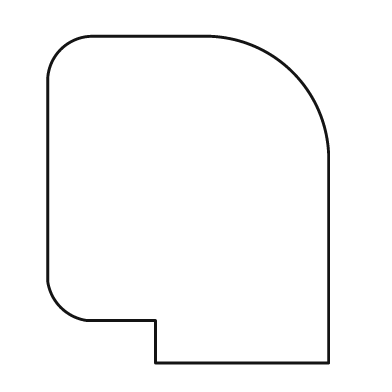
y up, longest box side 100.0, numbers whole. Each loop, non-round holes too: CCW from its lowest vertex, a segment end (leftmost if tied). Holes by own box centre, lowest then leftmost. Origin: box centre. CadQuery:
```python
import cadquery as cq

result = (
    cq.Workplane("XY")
    .moveTo(-10.0, -50.0)
    .lineTo(43.0, -50.0)
    .lineTo(43.0, 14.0)
    .threePointArc((32.0, 39.0), (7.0, 50.0))
    .lineTo(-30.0, 50.0)
    .threePointArc((-39.0, 46.0), (-43.0, 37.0))
    .lineTo(-43.0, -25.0)
    .threePointArc((-39.0, -33.0), (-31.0, -37.0))
    .lineTo(-10.0, -37.0)
    .close()
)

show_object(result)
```